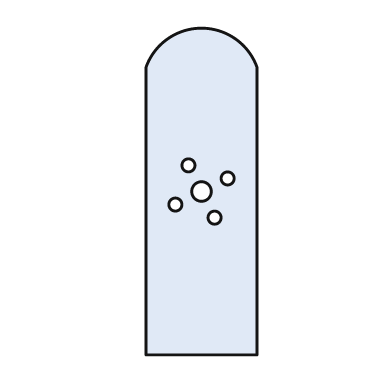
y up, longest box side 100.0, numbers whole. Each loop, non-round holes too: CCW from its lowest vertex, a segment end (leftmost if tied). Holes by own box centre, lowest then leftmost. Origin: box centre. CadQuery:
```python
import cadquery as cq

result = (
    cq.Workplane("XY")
    .moveTo(-17.0, -50.0)
    .lineTo(17.0, -50.0)
    .lineTo(17.0, 38.0)
    .threePointArc((0.0, 50.0), (-17.0, 38.0))
    .close()
    .moveTo(4.0, -8.0)
    .circle(2.0)
    .moveTo(-8.0, -4.0)
    .circle(2.0)
    .moveTo(0.0, 0.0)
    .circle(3.0)
    .moveTo(8.0, 4.0)
    .circle(2.0)
    .moveTo(-4.0, 8.0)
    .circle(2.0)
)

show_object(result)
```